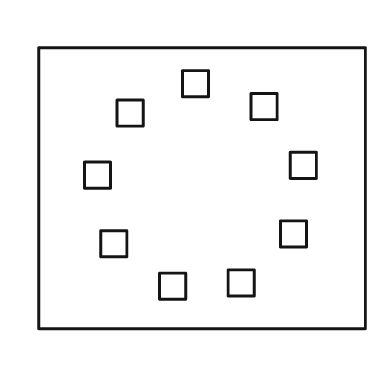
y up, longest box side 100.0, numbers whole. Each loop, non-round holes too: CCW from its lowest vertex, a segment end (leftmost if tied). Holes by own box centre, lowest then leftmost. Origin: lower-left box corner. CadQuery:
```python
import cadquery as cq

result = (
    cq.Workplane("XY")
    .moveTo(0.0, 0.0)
    .lineTo(100.0, 0.0)
    .lineTo(100.0, 86.0)
    .lineTo(0.0, 86.0)
    .close()
    .moveTo(37.0, 9.0)
    .lineTo(45.0, 9.0)
    .lineTo(45.0, 17.0)
    .lineTo(37.0, 17.0)
    .close()
    .moveTo(58.0, 10.0)
    .lineTo(66.0, 10.0)
    .lineTo(66.0, 18.0)
    .lineTo(58.0, 18.0)
    .close()
    .moveTo(19.0, 22.0)
    .lineTo(27.0, 22.0)
    .lineTo(27.0, 30.0)
    .lineTo(19.0, 30.0)
    .close()
    .moveTo(74.0, 25.0)
    .lineTo(82.0, 25.0)
    .lineTo(82.0, 33.0)
    .lineTo(74.0, 33.0)
    .close()
    .moveTo(14.0, 43.0)
    .lineTo(22.0, 43.0)
    .lineTo(22.0, 51.0)
    .lineTo(14.0, 51.0)
    .close()
    .moveTo(77.0, 46.0)
    .lineTo(85.0, 46.0)
    .lineTo(85.0, 54.0)
    .lineTo(77.0, 54.0)
    .close()
    .moveTo(24.0, 62.0)
    .lineTo(32.0, 62.0)
    .lineTo(32.0, 70.0)
    .lineTo(24.0, 70.0)
    .close()
    .moveTo(65.0, 64.0)
    .lineTo(73.0, 64.0)
    .lineTo(73.0, 72.0)
    .lineTo(65.0, 72.0)
    .close()
    .moveTo(44.0, 71.0)
    .lineTo(52.0, 71.0)
    .lineTo(52.0, 79.0)
    .lineTo(44.0, 79.0)
    .close()
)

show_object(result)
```